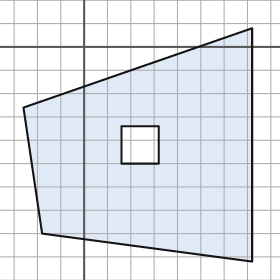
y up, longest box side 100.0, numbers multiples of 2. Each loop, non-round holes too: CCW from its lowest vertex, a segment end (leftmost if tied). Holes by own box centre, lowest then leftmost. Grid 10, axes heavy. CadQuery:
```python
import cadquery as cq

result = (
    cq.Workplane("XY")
    .moveTo(72.0, -92.0)
    .lineTo(72.0, 8.0)
    .lineTo(-26.0, -26.0)
    .lineTo(-18.0, -80.0)
    .close()
    .moveTo(16.0, -50.0)
    .lineTo(32.0, -50.0)
    .lineTo(32.0, -34.0)
    .lineTo(16.0, -34.0)
    .close()
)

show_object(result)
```